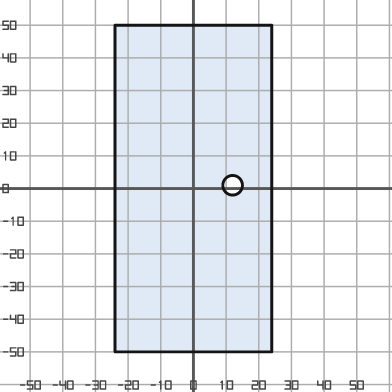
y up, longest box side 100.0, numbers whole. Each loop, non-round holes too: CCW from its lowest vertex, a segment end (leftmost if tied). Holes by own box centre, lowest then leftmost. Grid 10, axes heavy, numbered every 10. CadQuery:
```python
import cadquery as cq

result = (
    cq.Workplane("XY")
    .moveTo(-24.0, -50.0)
    .lineTo(24.0, -50.0)
    .lineTo(24.0, 50.0)
    .lineTo(-24.0, 50.0)
    .close()
    .moveTo(12.0, 1.0)
    .circle(3.0)
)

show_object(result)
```